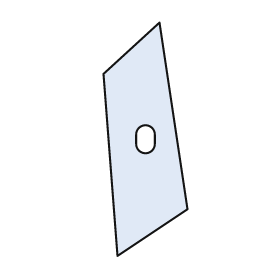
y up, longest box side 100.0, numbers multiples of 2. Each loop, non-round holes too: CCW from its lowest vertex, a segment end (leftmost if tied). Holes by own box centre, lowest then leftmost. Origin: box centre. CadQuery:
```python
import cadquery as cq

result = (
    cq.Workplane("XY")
    .moveTo(-12.0, -50.0)
    .lineTo(18.0, -30.0)
    .lineTo(6.0, 50.0)
    .lineTo(-18.0, 28.0)
    .close()
    .moveTo(-4.0, -2.0)
    .threePointArc((0.0, -6.0), (4.0, -2.0))
    .lineTo(4.0, 2.0)
    .threePointArc((0.0, 6.0), (-4.0, 2.0))
    .close()
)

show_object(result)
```